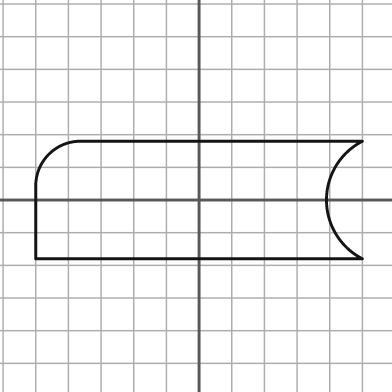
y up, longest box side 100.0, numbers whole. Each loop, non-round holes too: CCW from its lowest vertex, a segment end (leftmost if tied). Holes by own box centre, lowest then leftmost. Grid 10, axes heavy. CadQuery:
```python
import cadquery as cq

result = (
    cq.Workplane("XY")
    .moveTo(-50.0, -18.0)
    .lineTo(50.0, -18.0)
    .threePointArc((39.0, 0.0), (50.0, 18.0))
    .lineTo(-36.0, 18.0)
    .threePointArc((-46.0, 14.0), (-50.0, 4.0))
    .close()
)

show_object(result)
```